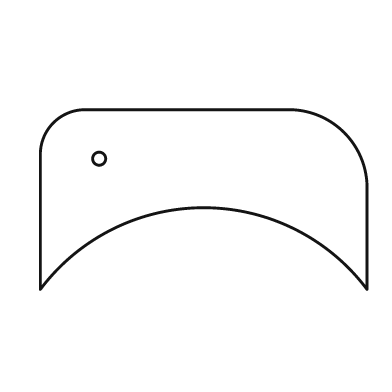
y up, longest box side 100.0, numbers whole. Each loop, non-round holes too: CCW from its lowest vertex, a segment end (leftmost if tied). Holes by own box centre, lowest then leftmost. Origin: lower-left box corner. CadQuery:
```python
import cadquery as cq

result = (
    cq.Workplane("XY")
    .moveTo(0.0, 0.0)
    .threePointArc((50.0, 25.0), (100.0, 0.0))
    .lineTo(100.0, 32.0)
    .threePointArc((93.0, 48.0), (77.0, 55.0))
    .lineTo(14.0, 55.0)
    .threePointArc((4.0, 51.0), (0.0, 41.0))
    .close()
    .moveTo(18.0, 40.0)
    .circle(2.0)
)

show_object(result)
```